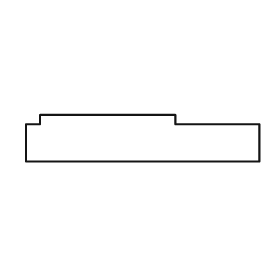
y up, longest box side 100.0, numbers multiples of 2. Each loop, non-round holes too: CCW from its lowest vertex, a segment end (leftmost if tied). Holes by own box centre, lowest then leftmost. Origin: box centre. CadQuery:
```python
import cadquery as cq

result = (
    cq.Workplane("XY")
    .moveTo(-50.0, -10.0)
    .lineTo(50.0, -10.0)
    .lineTo(50.0, 6.0)
    .lineTo(14.0, 6.0)
    .lineTo(14.0, 10.0)
    .lineTo(-44.0, 10.0)
    .lineTo(-44.0, 6.0)
    .lineTo(-50.0, 6.0)
    .close()
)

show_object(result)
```